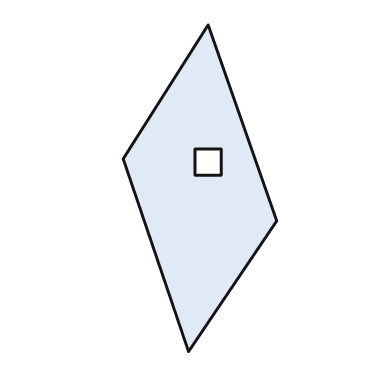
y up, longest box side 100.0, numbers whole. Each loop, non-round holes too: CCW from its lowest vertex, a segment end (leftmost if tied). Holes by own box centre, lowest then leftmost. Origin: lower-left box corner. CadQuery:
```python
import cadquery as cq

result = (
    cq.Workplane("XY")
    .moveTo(20.0, 0.0)
    .lineTo(47.0, 40.0)
    .lineTo(26.0, 100.0)
    .lineTo(0.0, 59.0)
    .close()
    .moveTo(22.0, 54.0)
    .lineTo(30.0, 54.0)
    .lineTo(30.0, 62.0)
    .lineTo(22.0, 62.0)
    .close()
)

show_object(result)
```